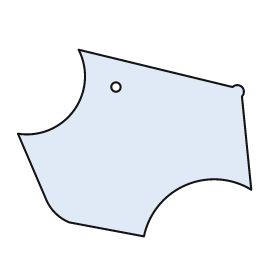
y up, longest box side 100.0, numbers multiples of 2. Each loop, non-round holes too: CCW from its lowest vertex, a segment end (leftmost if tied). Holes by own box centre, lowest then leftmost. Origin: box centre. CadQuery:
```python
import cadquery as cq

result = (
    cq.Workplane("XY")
    .moveTo(4.0, -40.0)
    .threePointArc((22.0, -18.0), (50.0, -20.0))
    .lineTo(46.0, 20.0)
    .threePointArc((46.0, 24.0), (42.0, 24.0))
    .lineTo(-24.0, 40.0)
    .threePointArc((-26.0, 14.0), (-50.0, 4.0))
    .lineTo(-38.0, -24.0)
    .threePointArc((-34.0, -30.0), (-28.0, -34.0))
    .close()
    .moveTo(-8.0, 24.0)
    .circle(2.0)
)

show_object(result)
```